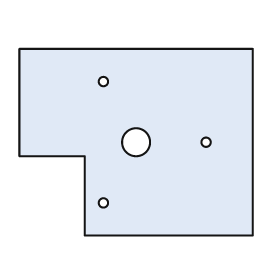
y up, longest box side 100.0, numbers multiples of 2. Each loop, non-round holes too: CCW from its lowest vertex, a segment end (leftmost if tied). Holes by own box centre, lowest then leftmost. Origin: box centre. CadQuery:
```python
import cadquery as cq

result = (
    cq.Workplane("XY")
    .moveTo(-22.0, -40.0)
    .lineTo(50.0, -40.0)
    .lineTo(50.0, 40.0)
    .lineTo(-50.0, 40.0)
    .lineTo(-50.0, -6.0)
    .lineTo(-22.0, -6.0)
    .close()
    .moveTo(-14.0, -26.0)
    .circle(2.0)
    .moveTo(0.0, 0.0)
    .circle(6.0)
    .moveTo(30.0, 0.0)
    .circle(2.0)
    .moveTo(-14.0, 26.0)
    .circle(2.0)
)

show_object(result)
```